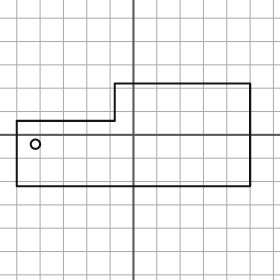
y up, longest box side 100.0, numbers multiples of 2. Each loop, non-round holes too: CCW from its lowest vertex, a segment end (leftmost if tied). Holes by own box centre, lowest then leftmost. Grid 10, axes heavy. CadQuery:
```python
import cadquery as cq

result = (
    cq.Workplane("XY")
    .moveTo(-50.0, -22.0)
    .lineTo(50.0, -22.0)
    .lineTo(50.0, 22.0)
    .lineTo(-8.0, 22.0)
    .lineTo(-8.0, 6.0)
    .lineTo(-50.0, 6.0)
    .close()
    .moveTo(-42.0, -4.0)
    .circle(2.0)
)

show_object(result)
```